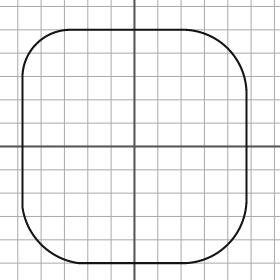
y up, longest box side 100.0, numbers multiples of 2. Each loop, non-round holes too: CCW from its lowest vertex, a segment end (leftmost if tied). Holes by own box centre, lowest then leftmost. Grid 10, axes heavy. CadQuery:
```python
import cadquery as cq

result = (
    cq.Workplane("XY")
    .moveTo(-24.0, -50.0)
    .lineTo(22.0, -50.0)
    .threePointArc((40.0, -42.0), (48.0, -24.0))
    .lineTo(48.0, 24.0)
    .threePointArc((40.0, 42.0), (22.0, 50.0))
    .lineTo(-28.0, 50.0)
    .threePointArc((-42.0, 44.0), (-48.0, 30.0))
    .lineTo(-48.0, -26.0)
    .threePointArc((-40.0, -42.0), (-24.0, -50.0))
    .close()
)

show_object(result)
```